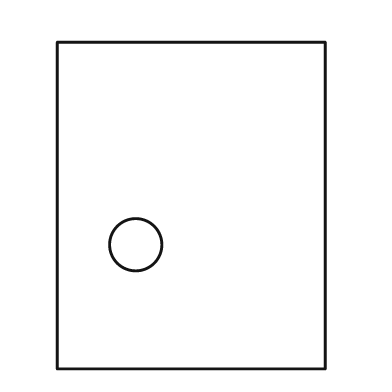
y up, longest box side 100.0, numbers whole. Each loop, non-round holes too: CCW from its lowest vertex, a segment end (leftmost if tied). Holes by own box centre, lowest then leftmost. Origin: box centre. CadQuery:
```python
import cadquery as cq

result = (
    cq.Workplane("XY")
    .moveTo(-41.0, -50.0)
    .lineTo(41.0, -50.0)
    .lineTo(41.0, 50.0)
    .lineTo(-41.0, 50.0)
    .close()
    .moveTo(-17.0, -12.0)
    .circle(8.0)
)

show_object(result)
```